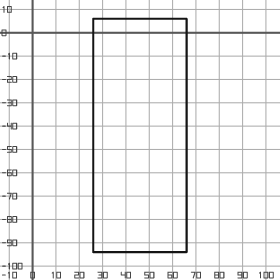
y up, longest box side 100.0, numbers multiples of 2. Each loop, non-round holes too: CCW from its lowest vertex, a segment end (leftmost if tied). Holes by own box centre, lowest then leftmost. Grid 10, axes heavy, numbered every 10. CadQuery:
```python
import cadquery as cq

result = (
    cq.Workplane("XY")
    .moveTo(26.0, -94.0)
    .lineTo(66.0, -94.0)
    .lineTo(66.0, 6.0)
    .lineTo(26.0, 6.0)
    .close()
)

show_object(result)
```